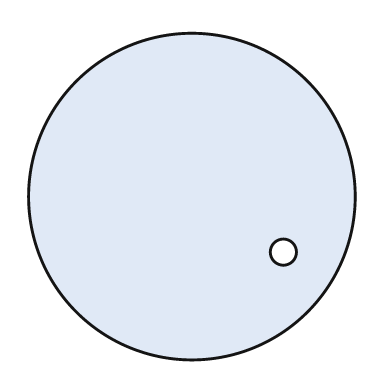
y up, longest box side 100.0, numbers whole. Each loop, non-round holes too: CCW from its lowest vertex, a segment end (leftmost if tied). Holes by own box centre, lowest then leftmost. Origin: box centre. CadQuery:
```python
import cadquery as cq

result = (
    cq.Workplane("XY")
    .moveTo(0.0, 0.0)
    .circle(50.0)
    .moveTo(28.0, -17.0)
    .circle(4.0)
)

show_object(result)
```